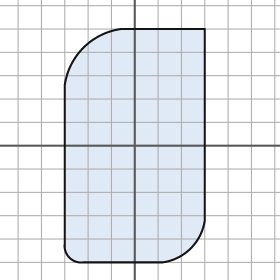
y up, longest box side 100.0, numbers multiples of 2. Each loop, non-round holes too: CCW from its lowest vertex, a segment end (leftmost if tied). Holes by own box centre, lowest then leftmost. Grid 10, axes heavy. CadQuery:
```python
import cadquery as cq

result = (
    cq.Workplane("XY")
    .moveTo(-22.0, -50.0)
    .lineTo(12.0, -50.0)
    .threePointArc((24.0, -44.0), (30.0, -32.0))
    .lineTo(30.0, 50.0)
    .lineTo(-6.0, 50.0)
    .threePointArc((-22.0, 42.0), (-30.0, 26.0))
    .lineTo(-30.0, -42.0)
    .threePointArc((-28.0, -48.0), (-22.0, -50.0))
    .close()
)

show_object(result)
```